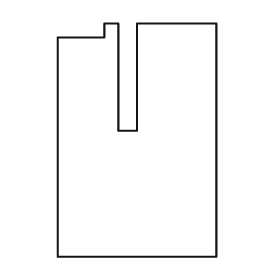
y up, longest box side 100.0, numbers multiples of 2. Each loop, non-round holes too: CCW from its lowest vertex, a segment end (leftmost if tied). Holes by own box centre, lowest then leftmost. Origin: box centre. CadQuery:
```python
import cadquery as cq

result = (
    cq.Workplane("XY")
    .moveTo(-34.0, -50.0)
    .lineTo(34.0, -50.0)
    .lineTo(34.0, 50.0)
    .lineTo(0.0, 50.0)
    .lineTo(0.0, 4.0)
    .lineTo(-8.0, 4.0)
    .lineTo(-8.0, 50.0)
    .lineTo(-14.0, 50.0)
    .lineTo(-14.0, 44.0)
    .lineTo(-34.0, 44.0)
    .close()
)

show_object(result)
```